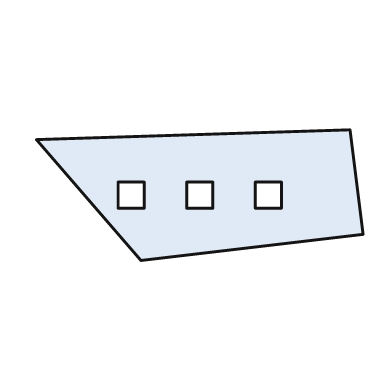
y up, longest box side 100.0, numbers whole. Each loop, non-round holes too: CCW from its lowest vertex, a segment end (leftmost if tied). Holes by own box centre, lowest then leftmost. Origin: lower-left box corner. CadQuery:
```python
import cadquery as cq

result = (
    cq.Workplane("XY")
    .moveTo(32.0, 0.0)
    .lineTo(100.0, 8.0)
    .lineTo(96.0, 40.0)
    .lineTo(0.0, 37.0)
    .close()
    .moveTo(25.0, 16.0)
    .lineTo(33.0, 16.0)
    .lineTo(33.0, 24.0)
    .lineTo(25.0, 24.0)
    .close()
    .moveTo(46.0, 16.0)
    .lineTo(54.0, 16.0)
    .lineTo(54.0, 24.0)
    .lineTo(46.0, 24.0)
    .close()
    .moveTo(67.0, 16.0)
    .lineTo(75.0, 16.0)
    .lineTo(75.0, 24.0)
    .lineTo(67.0, 24.0)
    .close()
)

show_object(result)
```